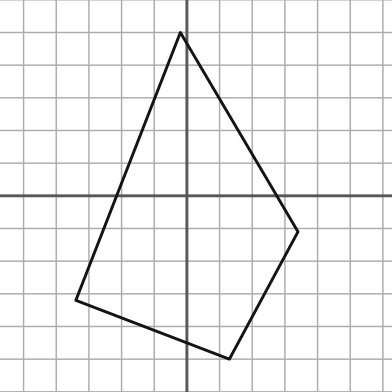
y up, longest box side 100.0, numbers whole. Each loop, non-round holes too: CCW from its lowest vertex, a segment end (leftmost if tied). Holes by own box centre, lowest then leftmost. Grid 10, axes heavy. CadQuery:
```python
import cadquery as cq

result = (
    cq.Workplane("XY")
    .moveTo(13.0, -50.0)
    .lineTo(34.0, -11.0)
    .lineTo(-2.0, 50.0)
    .lineTo(-34.0, -32.0)
    .close()
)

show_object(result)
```